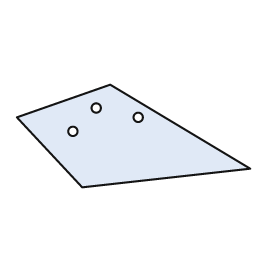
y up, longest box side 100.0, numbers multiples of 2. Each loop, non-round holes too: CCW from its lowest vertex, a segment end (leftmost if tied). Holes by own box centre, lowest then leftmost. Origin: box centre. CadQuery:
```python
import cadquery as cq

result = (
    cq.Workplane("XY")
    .moveTo(-22.0, -22.0)
    .lineTo(50.0, -14.0)
    .lineTo(-10.0, 22.0)
    .lineTo(-50.0, 8.0)
    .close()
    .moveTo(-26.0, 2.0)
    .circle(2.0)
    .moveTo(2.0, 8.0)
    .circle(2.0)
    .moveTo(-16.0, 12.0)
    .circle(2.0)
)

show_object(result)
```